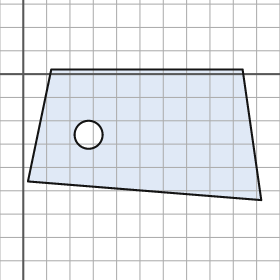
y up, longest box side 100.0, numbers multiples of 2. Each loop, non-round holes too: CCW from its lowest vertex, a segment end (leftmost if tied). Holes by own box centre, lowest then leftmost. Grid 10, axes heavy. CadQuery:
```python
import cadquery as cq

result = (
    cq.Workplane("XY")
    .moveTo(102.0, -54.0)
    .lineTo(94.0, 2.0)
    .lineTo(12.0, 2.0)
    .lineTo(2.0, -46.0)
    .close()
    .moveTo(28.0, -26.0)
    .circle(6.0)
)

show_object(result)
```